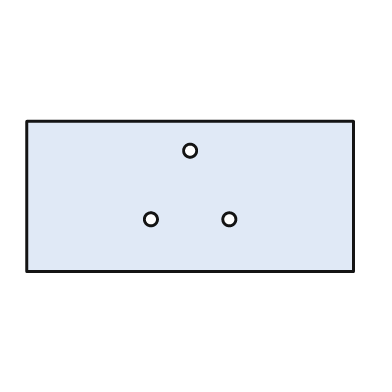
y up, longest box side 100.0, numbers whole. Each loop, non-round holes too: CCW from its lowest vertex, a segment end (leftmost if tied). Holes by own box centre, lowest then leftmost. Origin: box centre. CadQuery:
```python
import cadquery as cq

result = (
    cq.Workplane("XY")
    .moveTo(-50.0, -23.0)
    .lineTo(50.0, -23.0)
    .lineTo(50.0, 23.0)
    .lineTo(-50.0, 23.0)
    .close()
    .moveTo(-12.0, -7.0)
    .circle(2.0)
    .moveTo(12.0, -7.0)
    .circle(2.0)
    .moveTo(0.0, 14.0)
    .circle(2.0)
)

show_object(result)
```